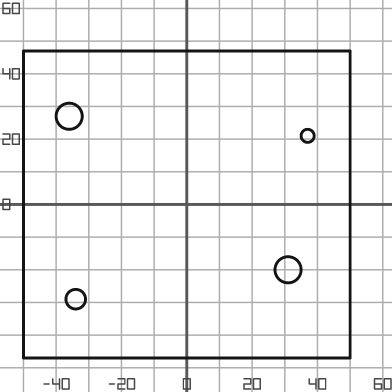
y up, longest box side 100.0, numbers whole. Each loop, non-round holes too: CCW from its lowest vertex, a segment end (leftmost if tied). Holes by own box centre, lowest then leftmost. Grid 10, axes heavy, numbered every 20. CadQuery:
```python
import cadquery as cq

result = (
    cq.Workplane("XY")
    .moveTo(-50.0, -47.0)
    .lineTo(50.0, -47.0)
    .lineTo(50.0, 47.0)
    .lineTo(-50.0, 47.0)
    .close()
    .moveTo(-34.0, -29.0)
    .circle(3.0)
    .moveTo(31.0, -20.0)
    .circle(4.0)
    .moveTo(37.0, 21.0)
    .circle(2.0)
    .moveTo(-36.0, 27.0)
    .circle(4.0)
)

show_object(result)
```